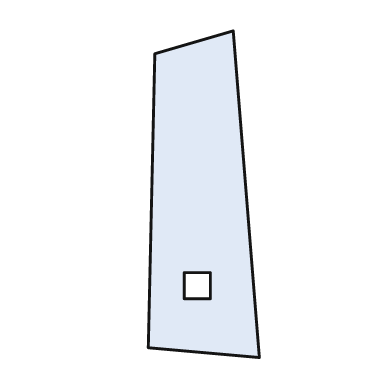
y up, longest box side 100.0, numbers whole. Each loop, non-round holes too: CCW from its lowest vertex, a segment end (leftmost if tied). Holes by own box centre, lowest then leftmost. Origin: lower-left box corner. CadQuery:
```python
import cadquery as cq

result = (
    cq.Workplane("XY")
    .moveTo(34.0, 0.0)
    .lineTo(26.0, 100.0)
    .lineTo(2.0, 93.0)
    .lineTo(0.0, 3.0)
    .close()
    .moveTo(11.0, 18.0)
    .lineTo(19.0, 18.0)
    .lineTo(19.0, 26.0)
    .lineTo(11.0, 26.0)
    .close()
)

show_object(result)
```